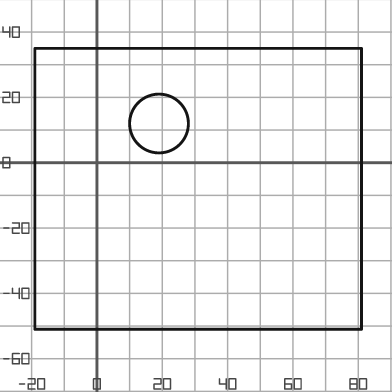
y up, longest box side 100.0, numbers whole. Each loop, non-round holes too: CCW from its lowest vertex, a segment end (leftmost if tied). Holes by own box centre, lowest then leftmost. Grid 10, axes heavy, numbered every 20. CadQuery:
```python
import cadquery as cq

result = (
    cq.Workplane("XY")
    .moveTo(-19.0, -51.0)
    .lineTo(81.0, -51.0)
    .lineTo(81.0, 35.0)
    .lineTo(-19.0, 35.0)
    .close()
    .moveTo(19.0, 12.0)
    .circle(9.0)
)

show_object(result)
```